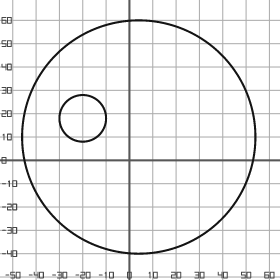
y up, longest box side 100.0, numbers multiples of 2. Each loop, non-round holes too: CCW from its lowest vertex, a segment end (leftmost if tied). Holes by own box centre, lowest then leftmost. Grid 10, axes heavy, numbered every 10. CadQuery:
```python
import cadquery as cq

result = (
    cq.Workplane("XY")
    .moveTo(4.0, 10.0)
    .circle(50.0)
    .moveTo(-20.0, 18.0)
    .circle(10.0)
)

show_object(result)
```